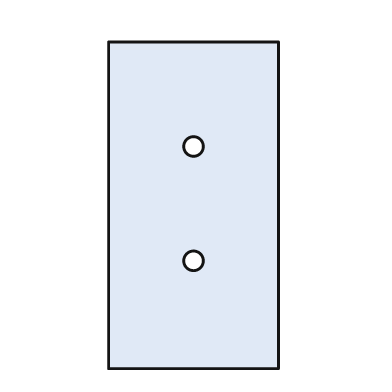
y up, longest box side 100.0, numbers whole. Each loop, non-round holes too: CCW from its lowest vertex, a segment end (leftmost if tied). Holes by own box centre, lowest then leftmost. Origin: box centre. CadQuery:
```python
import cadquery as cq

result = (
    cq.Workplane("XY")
    .moveTo(-26.0, -50.0)
    .lineTo(26.0, -50.0)
    .lineTo(26.0, 50.0)
    .lineTo(-26.0, 50.0)
    .close()
    .moveTo(0.0, -17.0)
    .circle(3.0)
    .moveTo(0.0, 18.0)
    .circle(3.0)
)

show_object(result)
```